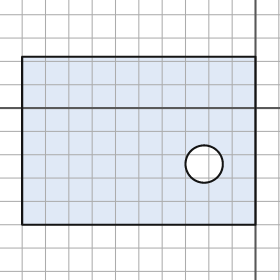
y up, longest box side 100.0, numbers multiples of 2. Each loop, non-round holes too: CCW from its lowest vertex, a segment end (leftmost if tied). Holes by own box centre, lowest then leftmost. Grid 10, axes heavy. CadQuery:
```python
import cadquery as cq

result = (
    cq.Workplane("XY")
    .moveTo(-100.0, -50.0)
    .lineTo(0.0, -50.0)
    .lineTo(0.0, 22.0)
    .lineTo(-100.0, 22.0)
    .close()
    .moveTo(-22.0, -24.0)
    .circle(8.0)
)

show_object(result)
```